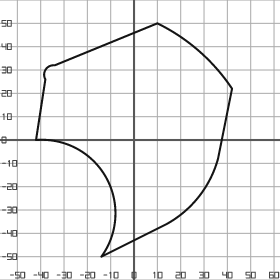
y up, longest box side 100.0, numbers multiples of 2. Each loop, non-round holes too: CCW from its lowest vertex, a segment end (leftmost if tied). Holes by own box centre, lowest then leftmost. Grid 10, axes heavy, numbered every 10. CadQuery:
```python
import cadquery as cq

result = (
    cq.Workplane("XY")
    .moveTo(-14.0, -50.0)
    .lineTo(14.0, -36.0)
    .threePointArc((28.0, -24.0), (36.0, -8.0))
    .lineTo(42.0, 22.0)
    .threePointArc((28.0, 38.0), (10.0, 50.0))
    .lineTo(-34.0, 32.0)
    .threePointArc((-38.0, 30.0), (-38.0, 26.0))
    .lineTo(-42.0, 0.0)
    .threePointArc((-12.0, -16.0), (-14.0, -50.0))
    .close()
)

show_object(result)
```